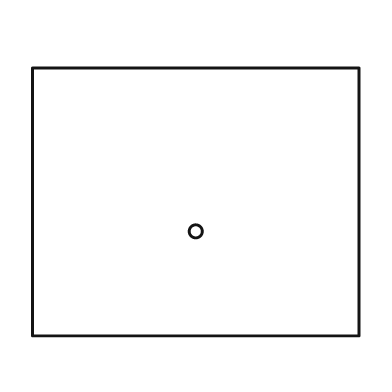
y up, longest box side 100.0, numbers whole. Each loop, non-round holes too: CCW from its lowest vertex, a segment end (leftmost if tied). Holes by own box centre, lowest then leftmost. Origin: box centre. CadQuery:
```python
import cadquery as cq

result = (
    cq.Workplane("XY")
    .moveTo(-50.0, -41.0)
    .lineTo(50.0, -41.0)
    .lineTo(50.0, 41.0)
    .lineTo(-50.0, 41.0)
    .close()
    .moveTo(0.0, -9.0)
    .circle(2.0)
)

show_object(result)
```